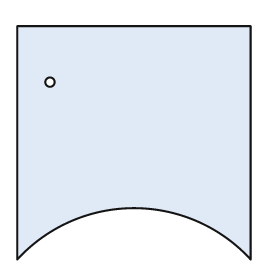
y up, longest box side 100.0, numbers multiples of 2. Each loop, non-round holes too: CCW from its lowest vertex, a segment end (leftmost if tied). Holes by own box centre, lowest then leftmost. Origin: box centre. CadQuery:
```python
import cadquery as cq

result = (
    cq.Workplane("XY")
    .moveTo(-50.0, -50.0)
    .threePointArc((0.0, -28.0), (50.0, -50.0))
    .lineTo(50.0, 50.0)
    .lineTo(-50.0, 50.0)
    .close()
    .moveTo(-36.0, 26.0)
    .circle(2.0)
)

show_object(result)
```